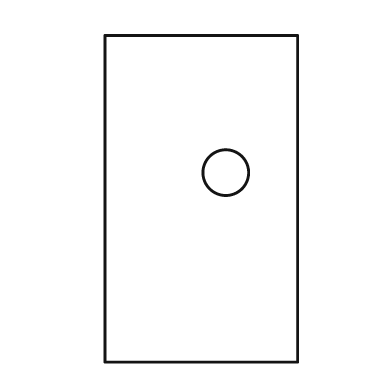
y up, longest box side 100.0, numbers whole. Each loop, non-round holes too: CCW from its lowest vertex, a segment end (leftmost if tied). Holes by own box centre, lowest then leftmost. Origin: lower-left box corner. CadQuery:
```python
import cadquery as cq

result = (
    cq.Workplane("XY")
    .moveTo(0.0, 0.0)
    .lineTo(59.0, 0.0)
    .lineTo(59.0, 100.0)
    .lineTo(0.0, 100.0)
    .close()
    .moveTo(37.0, 58.0)
    .circle(7.0)
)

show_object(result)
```